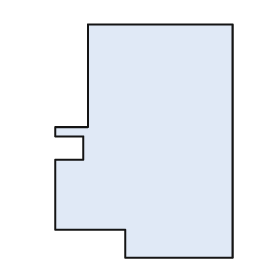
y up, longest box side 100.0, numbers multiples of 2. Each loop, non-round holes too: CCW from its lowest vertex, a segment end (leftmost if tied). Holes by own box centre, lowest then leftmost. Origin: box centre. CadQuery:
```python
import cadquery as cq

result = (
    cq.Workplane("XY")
    .moveTo(-8.0, -50.0)
    .lineTo(38.0, -50.0)
    .lineTo(38.0, 50.0)
    .lineTo(-24.0, 50.0)
    .lineTo(-24.0, 6.0)
    .lineTo(-38.0, 6.0)
    .lineTo(-38.0, 2.0)
    .lineTo(-26.0, 2.0)
    .lineTo(-26.0, -8.0)
    .lineTo(-38.0, -8.0)
    .lineTo(-38.0, -38.0)
    .lineTo(-8.0, -38.0)
    .close()
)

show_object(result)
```